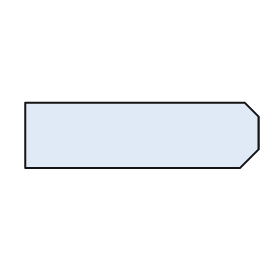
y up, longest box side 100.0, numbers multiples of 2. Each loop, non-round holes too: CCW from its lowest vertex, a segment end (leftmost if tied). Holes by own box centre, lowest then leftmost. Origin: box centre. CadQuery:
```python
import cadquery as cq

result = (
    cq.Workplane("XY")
    .moveTo(-50.0, -14.0)
    .lineTo(42.0, -14.0)
    .lineTo(50.0, -6.0)
    .lineTo(50.0, 8.0)
    .lineTo(44.0, 14.0)
    .lineTo(-50.0, 14.0)
    .close()
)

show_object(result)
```